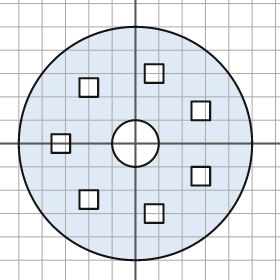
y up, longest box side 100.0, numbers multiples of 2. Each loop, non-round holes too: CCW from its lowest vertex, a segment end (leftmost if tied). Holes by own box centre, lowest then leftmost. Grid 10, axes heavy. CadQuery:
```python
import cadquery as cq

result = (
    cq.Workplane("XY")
    .moveTo(0.0, 0.0)
    .circle(50.0)
    .moveTo(4.0, -34.0)
    .lineTo(12.0, -34.0)
    .lineTo(12.0, -26.0)
    .lineTo(4.0, -26.0)
    .close()
    .moveTo(-24.0, -28.0)
    .lineTo(-16.0, -28.0)
    .lineTo(-16.0, -20.0)
    .lineTo(-24.0, -20.0)
    .close()
    .moveTo(24.0, -18.0)
    .lineTo(32.0, -18.0)
    .lineTo(32.0, -10.0)
    .lineTo(24.0, -10.0)
    .close()
    .moveTo(-36.0, -4.0)
    .lineTo(-28.0, -4.0)
    .lineTo(-28.0, 4.0)
    .lineTo(-36.0, 4.0)
    .close()
    .moveTo(0.0, 0.0)
    .circle(10.0)
    .moveTo(24.0, 10.0)
    .lineTo(32.0, 10.0)
    .lineTo(32.0, 18.0)
    .lineTo(24.0, 18.0)
    .close()
    .moveTo(-24.0, 20.0)
    .lineTo(-16.0, 20.0)
    .lineTo(-16.0, 28.0)
    .lineTo(-24.0, 28.0)
    .close()
    .moveTo(4.0, 26.0)
    .lineTo(12.0, 26.0)
    .lineTo(12.0, 34.0)
    .lineTo(4.0, 34.0)
    .close()
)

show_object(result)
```